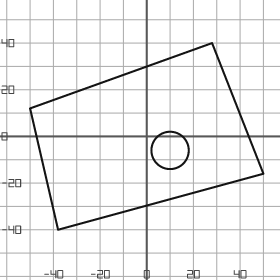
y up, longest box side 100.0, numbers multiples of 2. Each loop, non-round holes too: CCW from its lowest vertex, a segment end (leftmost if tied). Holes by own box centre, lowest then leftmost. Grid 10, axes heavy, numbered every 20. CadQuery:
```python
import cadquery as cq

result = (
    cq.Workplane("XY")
    .moveTo(-38.0, -40.0)
    .lineTo(50.0, -16.0)
    .lineTo(28.0, 40.0)
    .lineTo(-50.0, 12.0)
    .close()
    .moveTo(10.0, -6.0)
    .circle(8.0)
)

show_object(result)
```